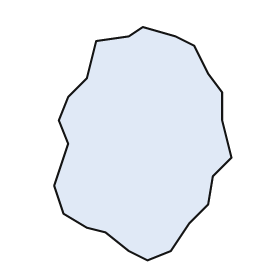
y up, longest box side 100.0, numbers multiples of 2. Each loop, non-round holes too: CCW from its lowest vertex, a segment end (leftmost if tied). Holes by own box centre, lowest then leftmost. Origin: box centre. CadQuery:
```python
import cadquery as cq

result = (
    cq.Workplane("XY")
    .moveTo(2.0, -50.0)
    .lineTo(12.0, -46.0)
    .lineTo(20.0, -34.0)
    .lineTo(28.0, -26.0)
    .lineTo(30.0, -14.0)
    .lineTo(38.0, -6.0)
    .lineTo(34.0, 10.0)
    .lineTo(34.0, 22.0)
    .lineTo(28.0, 30.0)
    .lineTo(22.0, 42.0)
    .lineTo(14.0, 46.0)
    .lineTo(0.0, 50.0)
    .lineTo(-6.0, 46.0)
    .lineTo(-20.0, 44.0)
    .lineTo(-24.0, 28.0)
    .lineTo(-32.0, 20.0)
    .lineTo(-36.0, 10.0)
    .lineTo(-32.0, 0.0)
    .lineTo(-38.0, -18.0)
    .lineTo(-34.0, -30.0)
    .lineTo(-24.0, -36.0)
    .lineTo(-16.0, -38.0)
    .lineTo(-6.0, -46.0)
    .close()
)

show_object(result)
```